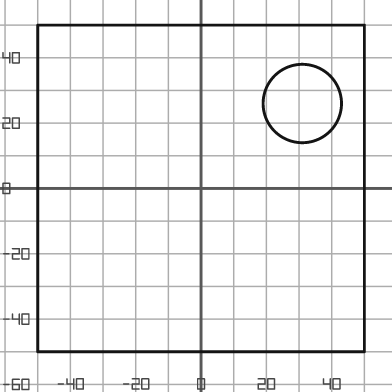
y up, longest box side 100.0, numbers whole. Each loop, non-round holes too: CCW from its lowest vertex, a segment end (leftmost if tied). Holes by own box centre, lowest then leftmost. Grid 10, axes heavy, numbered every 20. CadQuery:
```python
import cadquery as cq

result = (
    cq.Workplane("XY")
    .moveTo(-50.0, -50.0)
    .lineTo(50.0, -50.0)
    .lineTo(50.0, 50.0)
    .lineTo(-50.0, 50.0)
    .close()
    .moveTo(31.0, 26.0)
    .circle(12.0)
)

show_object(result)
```